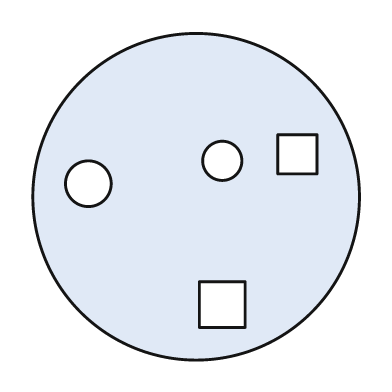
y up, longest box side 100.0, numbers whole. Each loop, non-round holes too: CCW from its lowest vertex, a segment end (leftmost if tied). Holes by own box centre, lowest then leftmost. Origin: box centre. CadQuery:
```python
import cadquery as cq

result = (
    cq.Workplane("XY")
    .moveTo(0.0, 0.0)
    .circle(50.0)
    .moveTo(1.0, -40.0)
    .lineTo(15.0, -40.0)
    .lineTo(15.0, -26.0)
    .lineTo(1.0, -26.0)
    .close()
    .moveTo(-33.0, 4.0)
    .circle(7.0)
    .moveTo(8.0, 11.0)
    .circle(6.0)
    .moveTo(25.0, 7.0)
    .lineTo(37.0, 7.0)
    .lineTo(37.0, 19.0)
    .lineTo(25.0, 19.0)
    .close()
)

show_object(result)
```